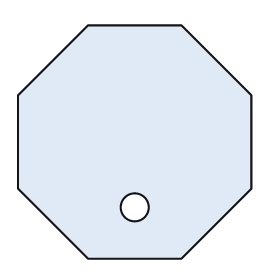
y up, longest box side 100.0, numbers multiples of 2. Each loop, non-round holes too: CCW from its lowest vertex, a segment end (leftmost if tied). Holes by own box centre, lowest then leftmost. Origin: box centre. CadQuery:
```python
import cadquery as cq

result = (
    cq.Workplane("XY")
    .moveTo(-20.0, -50.0)
    .lineTo(20.0, -50.0)
    .lineTo(50.0, -20.0)
    .lineTo(50.0, 20.0)
    .lineTo(20.0, 50.0)
    .lineTo(-20.0, 50.0)
    .lineTo(-50.0, 20.0)
    .lineTo(-50.0, -20.0)
    .close()
    .moveTo(0.0, -28.0)
    .circle(6.0)
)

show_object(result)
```